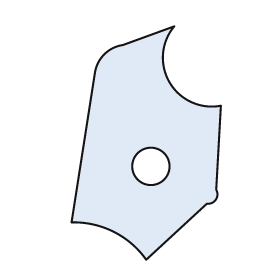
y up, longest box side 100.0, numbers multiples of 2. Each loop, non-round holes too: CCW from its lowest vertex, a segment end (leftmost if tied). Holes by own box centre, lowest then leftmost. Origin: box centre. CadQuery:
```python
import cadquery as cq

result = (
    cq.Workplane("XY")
    .moveTo(0.0, -50.0)
    .lineTo(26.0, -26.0)
    .threePointArc((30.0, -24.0), (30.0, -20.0))
    .lineTo(32.0, 16.0)
    .threePointArc((10.0, 26.0), (12.0, 50.0))
    .lineTo(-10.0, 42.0)
    .threePointArc((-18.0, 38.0), (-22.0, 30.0))
    .lineTo(-32.0, -34.0)
    .threePointArc((-14.0, -38.0), (0.0, -50.0))
    .close()
    .moveTo(2.0, -10.0)
    .circle(8.0)
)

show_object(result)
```